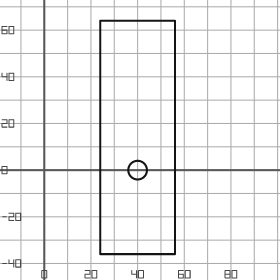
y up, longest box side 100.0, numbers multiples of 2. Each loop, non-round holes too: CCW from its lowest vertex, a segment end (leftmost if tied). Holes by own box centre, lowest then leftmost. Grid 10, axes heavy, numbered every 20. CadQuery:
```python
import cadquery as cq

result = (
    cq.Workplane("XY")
    .moveTo(24.0, -36.0)
    .lineTo(56.0, -36.0)
    .lineTo(56.0, 64.0)
    .lineTo(24.0, 64.0)
    .close()
    .moveTo(40.0, 0.0)
    .circle(4.0)
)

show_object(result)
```